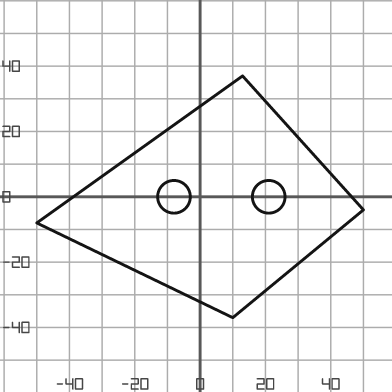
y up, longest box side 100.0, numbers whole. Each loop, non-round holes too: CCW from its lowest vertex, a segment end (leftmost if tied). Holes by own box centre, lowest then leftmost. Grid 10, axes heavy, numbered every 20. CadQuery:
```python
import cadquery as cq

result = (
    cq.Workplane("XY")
    .moveTo(10.0, -37.0)
    .lineTo(50.0, -4.0)
    .lineTo(13.0, 37.0)
    .lineTo(-50.0, -8.0)
    .close()
    .moveTo(-8.0, 0.0)
    .circle(5.0)
    .moveTo(21.0, 0.0)
    .circle(5.0)
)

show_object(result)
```